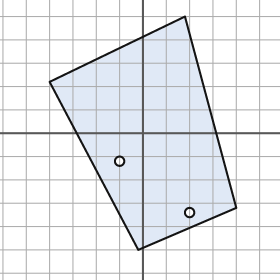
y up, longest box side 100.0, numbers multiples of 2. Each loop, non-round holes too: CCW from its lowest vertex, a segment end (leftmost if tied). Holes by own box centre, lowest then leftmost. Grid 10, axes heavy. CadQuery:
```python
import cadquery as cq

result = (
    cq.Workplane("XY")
    .moveTo(-2.0, -50.0)
    .lineTo(40.0, -32.0)
    .lineTo(18.0, 50.0)
    .lineTo(-40.0, 22.0)
    .close()
    .moveTo(20.0, -34.0)
    .circle(2.0)
    .moveTo(-10.0, -12.0)
    .circle(2.0)
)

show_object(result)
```